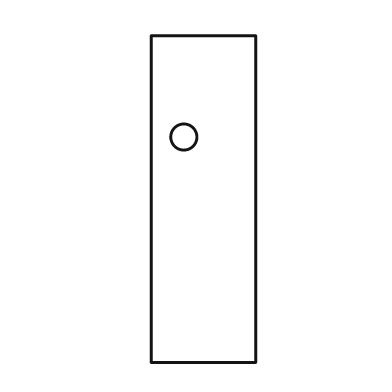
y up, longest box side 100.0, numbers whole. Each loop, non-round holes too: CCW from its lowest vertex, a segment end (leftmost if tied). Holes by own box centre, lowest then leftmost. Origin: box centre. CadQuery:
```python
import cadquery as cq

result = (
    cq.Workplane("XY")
    .moveTo(-16.0, -50.0)
    .lineTo(16.0, -50.0)
    .lineTo(16.0, 50.0)
    .lineTo(-16.0, 50.0)
    .close()
    .moveTo(-6.0, 19.0)
    .circle(4.0)
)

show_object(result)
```